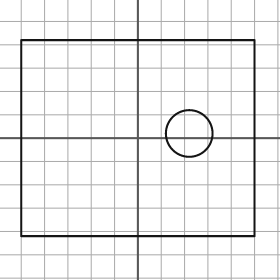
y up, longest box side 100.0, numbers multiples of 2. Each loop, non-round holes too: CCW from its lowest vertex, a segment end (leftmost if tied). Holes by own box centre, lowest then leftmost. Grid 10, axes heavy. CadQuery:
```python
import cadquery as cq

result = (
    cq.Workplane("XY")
    .moveTo(-50.0, -42.0)
    .lineTo(50.0, -42.0)
    .lineTo(50.0, 42.0)
    .lineTo(-50.0, 42.0)
    .close()
    .moveTo(22.0, 2.0)
    .circle(10.0)
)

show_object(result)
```